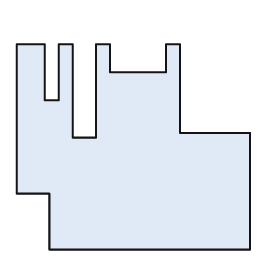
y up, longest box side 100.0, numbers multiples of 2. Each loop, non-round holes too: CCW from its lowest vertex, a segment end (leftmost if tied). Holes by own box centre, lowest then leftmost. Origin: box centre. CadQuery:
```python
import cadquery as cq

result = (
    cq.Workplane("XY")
    .moveTo(-36.0, -44.0)
    .lineTo(50.0, -44.0)
    .lineTo(50.0, 6.0)
    .lineTo(20.0, 6.0)
    .lineTo(20.0, 44.0)
    .lineTo(14.0, 44.0)
    .lineTo(14.0, 32.0)
    .lineTo(-10.0, 32.0)
    .lineTo(-10.0, 44.0)
    .lineTo(-16.0, 44.0)
    .lineTo(-16.0, 4.0)
    .lineTo(-26.0, 4.0)
    .lineTo(-26.0, 44.0)
    .lineTo(-32.0, 44.0)
    .lineTo(-32.0, 20.0)
    .lineTo(-38.0, 20.0)
    .lineTo(-38.0, 44.0)
    .lineTo(-50.0, 44.0)
    .lineTo(-50.0, -20.0)
    .lineTo(-36.0, -20.0)
    .close()
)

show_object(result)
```